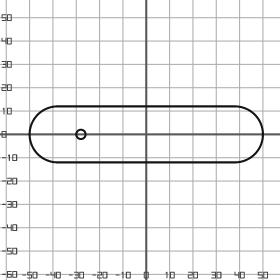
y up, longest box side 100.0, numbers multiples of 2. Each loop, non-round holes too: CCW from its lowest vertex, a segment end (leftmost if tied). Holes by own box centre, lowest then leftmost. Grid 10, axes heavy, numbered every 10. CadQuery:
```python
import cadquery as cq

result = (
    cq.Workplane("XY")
    .moveTo(-38.0, -12.0)
    .lineTo(38.0, -12.0)
    .threePointArc((50.0, 0.0), (38.0, 12.0))
    .lineTo(-38.0, 12.0)
    .threePointArc((-50.0, 0.0), (-38.0, -12.0))
    .close()
    .moveTo(-28.0, 0.0)
    .circle(2.0)
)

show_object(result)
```